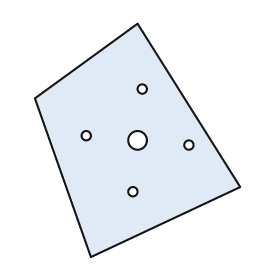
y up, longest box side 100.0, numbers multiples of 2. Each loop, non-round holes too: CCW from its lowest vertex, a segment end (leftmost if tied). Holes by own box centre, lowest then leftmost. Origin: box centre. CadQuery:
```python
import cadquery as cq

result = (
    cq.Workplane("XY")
    .moveTo(-20.0, -50.0)
    .lineTo(44.0, -20.0)
    .lineTo(0.0, 50.0)
    .lineTo(-44.0, 18.0)
    .close()
    .moveTo(-2.0, -22.0)
    .circle(2.0)
    .moveTo(22.0, -2.0)
    .circle(2.0)
    .moveTo(0.0, 0.0)
    .circle(4.0)
    .moveTo(-22.0, 2.0)
    .circle(2.0)
    .moveTo(2.0, 22.0)
    .circle(2.0)
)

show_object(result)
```